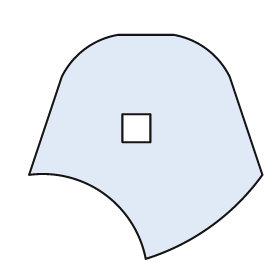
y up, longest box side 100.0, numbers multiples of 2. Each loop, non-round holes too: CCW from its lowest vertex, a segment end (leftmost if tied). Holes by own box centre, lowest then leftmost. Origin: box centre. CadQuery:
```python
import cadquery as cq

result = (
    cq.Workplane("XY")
    .moveTo(0.0, -48.0)
    .threePointArc((28.0, -34.0), (50.0, -12.0))
    .lineTo(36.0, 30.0)
    .threePointArc((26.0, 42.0), (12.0, 48.0))
    .lineTo(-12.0, 48.0)
    .threePointArc((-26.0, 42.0), (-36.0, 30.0))
    .lineTo(-50.0, -12.0)
    .threePointArc((-18.0, -20.0), (0.0, -48.0))
    .close()
    .moveTo(-10.0, 2.0)
    .lineTo(2.0, 2.0)
    .lineTo(2.0, 14.0)
    .lineTo(-10.0, 14.0)
    .close()
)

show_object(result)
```